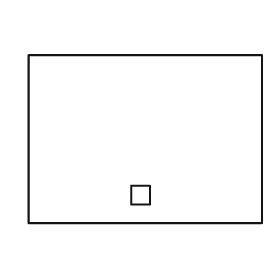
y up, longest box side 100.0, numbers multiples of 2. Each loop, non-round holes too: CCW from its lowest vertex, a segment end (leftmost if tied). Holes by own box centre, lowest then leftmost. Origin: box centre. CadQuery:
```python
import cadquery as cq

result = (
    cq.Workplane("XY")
    .moveTo(-50.0, -36.0)
    .lineTo(50.0, -36.0)
    .lineTo(50.0, 36.0)
    .lineTo(-50.0, 36.0)
    .close()
    .moveTo(-6.0, -28.0)
    .lineTo(2.0, -28.0)
    .lineTo(2.0, -20.0)
    .lineTo(-6.0, -20.0)
    .close()
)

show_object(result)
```